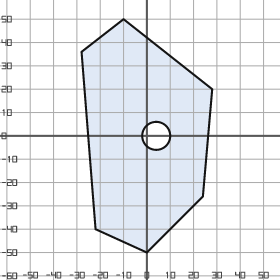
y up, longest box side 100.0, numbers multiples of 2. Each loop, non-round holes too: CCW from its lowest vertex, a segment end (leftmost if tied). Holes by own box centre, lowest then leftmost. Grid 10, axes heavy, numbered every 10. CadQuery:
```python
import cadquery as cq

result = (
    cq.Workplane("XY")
    .moveTo(0.0, -50.0)
    .lineTo(24.0, -26.0)
    .lineTo(28.0, 20.0)
    .lineTo(-10.0, 50.0)
    .lineTo(-28.0, 36.0)
    .lineTo(-22.0, -40.0)
    .close()
    .moveTo(4.0, 0.0)
    .circle(6.0)
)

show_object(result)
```